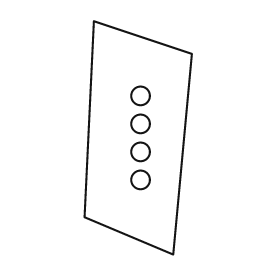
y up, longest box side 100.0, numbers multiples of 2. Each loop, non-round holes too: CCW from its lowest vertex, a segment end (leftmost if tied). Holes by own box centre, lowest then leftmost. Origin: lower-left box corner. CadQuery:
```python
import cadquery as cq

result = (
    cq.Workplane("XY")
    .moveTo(38.0, 0.0)
    .lineTo(46.0, 86.0)
    .lineTo(4.0, 100.0)
    .lineTo(0.0, 16.0)
    .close()
    .moveTo(24.0, 32.0)
    .circle(4.0)
    .moveTo(24.0, 44.0)
    .circle(4.0)
    .moveTo(24.0, 56.0)
    .circle(4.0)
    .moveTo(24.0, 68.0)
    .circle(4.0)
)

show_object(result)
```